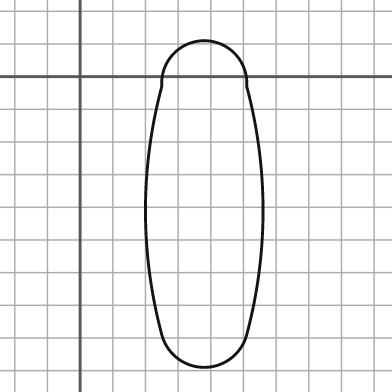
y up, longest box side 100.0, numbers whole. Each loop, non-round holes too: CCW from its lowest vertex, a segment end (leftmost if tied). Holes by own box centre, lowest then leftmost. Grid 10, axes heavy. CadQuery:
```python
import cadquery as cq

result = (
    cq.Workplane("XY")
    .moveTo(25.0, -79.0)
    .threePointArc((38.0, -89.0), (51.0, -79.0))
    .threePointArc((56.0, -41.0), (51.0, -3.0))
    .threePointArc((38.0, 11.0), (25.0, -3.0))
    .threePointArc((20.0, -41.0), (25.0, -79.0))
    .close()
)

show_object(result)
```